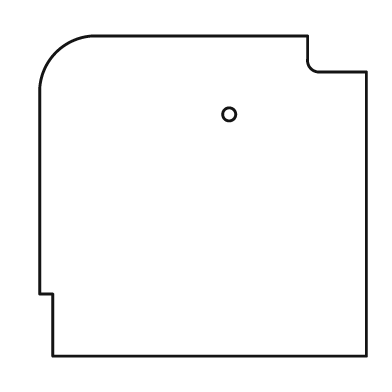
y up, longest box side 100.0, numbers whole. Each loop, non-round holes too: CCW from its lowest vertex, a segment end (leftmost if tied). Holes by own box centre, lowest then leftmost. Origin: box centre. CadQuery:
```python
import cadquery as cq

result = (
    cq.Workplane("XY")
    .moveTo(-46.0, -49.0)
    .lineTo(50.0, -49.0)
    .lineTo(50.0, 38.0)
    .lineTo(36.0, 38.0)
    .threePointArc((33.0, 39.0), (32.0, 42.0))
    .lineTo(32.0, 49.0)
    .lineTo(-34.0, 49.0)
    .threePointArc((-45.0, 44.0), (-50.0, 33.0))
    .lineTo(-50.0, -30.0)
    .lineTo(-46.0, -30.0)
    .close()
    .moveTo(8.0, 25.0)
    .circle(2.0)
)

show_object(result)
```